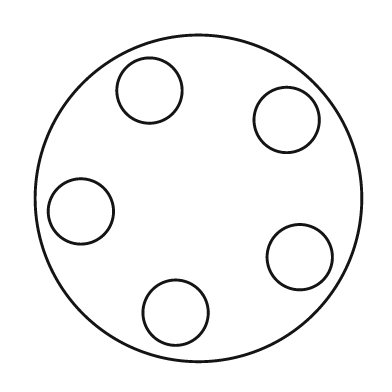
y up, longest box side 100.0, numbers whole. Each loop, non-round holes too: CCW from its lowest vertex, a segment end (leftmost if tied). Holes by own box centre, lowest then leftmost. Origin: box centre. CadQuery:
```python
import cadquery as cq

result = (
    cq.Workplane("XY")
    .moveTo(0.0, 0.0)
    .circle(50.0)
    .moveTo(-7.0, -35.0)
    .circle(10.0)
    .moveTo(31.0, -18.0)
    .circle(10.0)
    .moveTo(-36.0, -4.0)
    .circle(10.0)
    .moveTo(27.0, 24.0)
    .circle(10.0)
    .moveTo(-15.0, 33.0)
    .circle(10.0)
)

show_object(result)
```